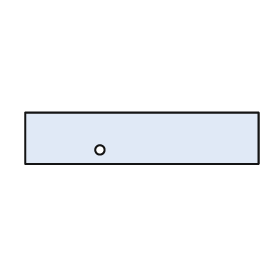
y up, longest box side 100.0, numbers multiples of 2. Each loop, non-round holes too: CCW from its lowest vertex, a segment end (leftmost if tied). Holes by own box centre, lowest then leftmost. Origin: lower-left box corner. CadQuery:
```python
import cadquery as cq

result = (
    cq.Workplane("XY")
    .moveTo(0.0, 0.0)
    .lineTo(100.0, 0.0)
    .lineTo(100.0, 22.0)
    .lineTo(0.0, 22.0)
    .close()
    .moveTo(32.0, 6.0)
    .circle(2.0)
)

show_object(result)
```